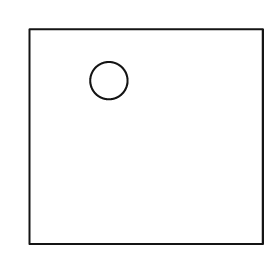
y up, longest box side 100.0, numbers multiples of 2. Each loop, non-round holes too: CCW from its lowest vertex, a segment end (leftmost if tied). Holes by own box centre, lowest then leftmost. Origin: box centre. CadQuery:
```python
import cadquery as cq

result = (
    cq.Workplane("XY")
    .moveTo(-50.0, -46.0)
    .lineTo(50.0, -46.0)
    .lineTo(50.0, 46.0)
    .lineTo(-50.0, 46.0)
    .close()
    .moveTo(-16.0, 24.0)
    .circle(8.0)
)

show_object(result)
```